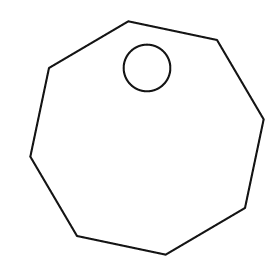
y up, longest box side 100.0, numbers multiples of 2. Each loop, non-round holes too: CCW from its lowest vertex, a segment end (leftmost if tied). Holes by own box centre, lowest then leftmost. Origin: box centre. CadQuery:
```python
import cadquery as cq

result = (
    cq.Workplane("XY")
    .moveTo(8.0, -50.0)
    .lineTo(42.0, -30.0)
    .lineTo(50.0, 8.0)
    .lineTo(30.0, 42.0)
    .lineTo(-8.0, 50.0)
    .lineTo(-42.0, 30.0)
    .lineTo(-50.0, -8.0)
    .lineTo(-30.0, -42.0)
    .close()
    .moveTo(0.0, 30.0)
    .circle(10.0)
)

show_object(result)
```